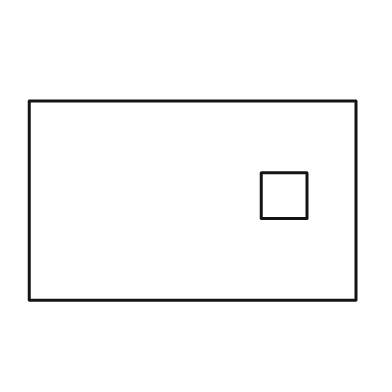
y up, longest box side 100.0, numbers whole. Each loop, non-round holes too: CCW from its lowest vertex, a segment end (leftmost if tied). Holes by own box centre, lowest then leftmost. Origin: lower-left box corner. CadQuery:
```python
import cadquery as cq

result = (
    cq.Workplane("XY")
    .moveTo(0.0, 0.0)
    .lineTo(100.0, 0.0)
    .lineTo(100.0, 61.0)
    .lineTo(0.0, 61.0)
    .close()
    .moveTo(71.0, 25.0)
    .lineTo(85.0, 25.0)
    .lineTo(85.0, 39.0)
    .lineTo(71.0, 39.0)
    .close()
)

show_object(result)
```